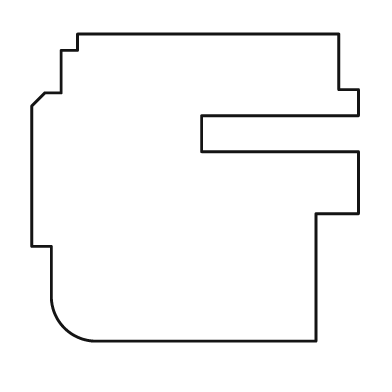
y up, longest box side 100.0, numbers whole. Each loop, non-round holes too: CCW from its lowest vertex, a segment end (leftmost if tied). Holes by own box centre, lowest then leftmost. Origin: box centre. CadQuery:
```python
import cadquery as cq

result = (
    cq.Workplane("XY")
    .moveTo(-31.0, -47.0)
    .lineTo(37.0, -47.0)
    .lineTo(37.0, -8.0)
    .lineTo(50.0, -8.0)
    .lineTo(50.0, 11.0)
    .lineTo(2.0, 11.0)
    .lineTo(2.0, 22.0)
    .lineTo(50.0, 22.0)
    .lineTo(50.0, 30.0)
    .lineTo(44.0, 30.0)
    .lineTo(44.0, 47.0)
    .lineTo(-36.0, 47.0)
    .lineTo(-36.0, 42.0)
    .lineTo(-41.0, 42.0)
    .lineTo(-41.0, 29.0)
    .lineTo(-46.0, 29.0)
    .lineTo(-50.0, 25.0)
    .lineTo(-50.0, -18.0)
    .lineTo(-44.0, -18.0)
    .lineTo(-44.0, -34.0)
    .threePointArc((-40.0, -43.0), (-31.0, -47.0))
    .close()
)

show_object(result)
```